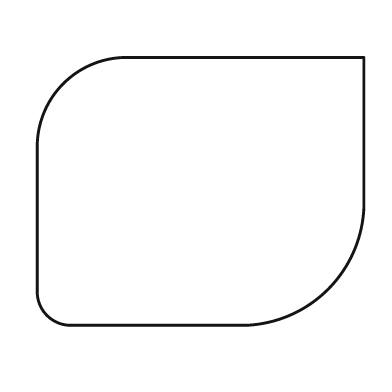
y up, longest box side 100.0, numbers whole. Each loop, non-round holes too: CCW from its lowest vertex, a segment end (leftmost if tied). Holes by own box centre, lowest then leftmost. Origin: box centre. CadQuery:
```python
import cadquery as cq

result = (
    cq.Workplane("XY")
    .moveTo(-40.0, -41.0)
    .lineTo(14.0, -41.0)
    .threePointArc((39.0, -30.0), (50.0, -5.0))
    .lineTo(50.0, 41.0)
    .lineTo(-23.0, 41.0)
    .threePointArc((-42.0, 33.0), (-50.0, 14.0))
    .lineTo(-50.0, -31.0)
    .threePointArc((-47.0, -38.0), (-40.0, -41.0))
    .close()
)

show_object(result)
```